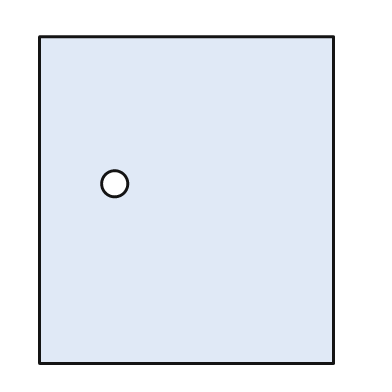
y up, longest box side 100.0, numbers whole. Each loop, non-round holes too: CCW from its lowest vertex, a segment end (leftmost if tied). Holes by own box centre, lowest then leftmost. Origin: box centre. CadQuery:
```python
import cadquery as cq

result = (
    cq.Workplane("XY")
    .moveTo(-45.0, -50.0)
    .lineTo(45.0, -50.0)
    .lineTo(45.0, 50.0)
    .lineTo(-45.0, 50.0)
    .close()
    .moveTo(-22.0, 5.0)
    .circle(4.0)
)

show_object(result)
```